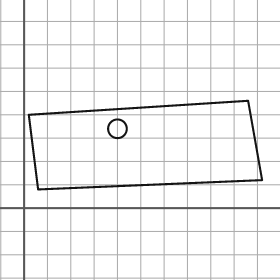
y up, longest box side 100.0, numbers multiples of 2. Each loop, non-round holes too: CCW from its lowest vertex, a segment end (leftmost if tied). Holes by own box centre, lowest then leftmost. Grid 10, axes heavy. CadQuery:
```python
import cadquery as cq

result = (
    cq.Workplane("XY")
    .moveTo(6.0, 8.0)
    .lineTo(102.0, 12.0)
    .lineTo(96.0, 46.0)
    .lineTo(2.0, 40.0)
    .close()
    .moveTo(40.0, 34.0)
    .circle(4.0)
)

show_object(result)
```